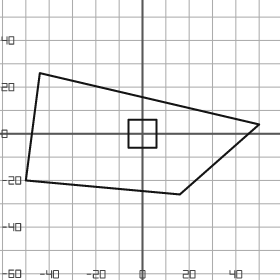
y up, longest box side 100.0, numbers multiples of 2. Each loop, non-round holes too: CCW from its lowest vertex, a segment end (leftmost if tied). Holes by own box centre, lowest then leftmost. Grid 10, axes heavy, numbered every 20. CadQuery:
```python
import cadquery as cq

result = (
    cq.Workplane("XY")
    .moveTo(16.0, -26.0)
    .lineTo(50.0, 4.0)
    .lineTo(-44.0, 26.0)
    .lineTo(-50.0, -20.0)
    .close()
    .moveTo(-6.0, -6.0)
    .lineTo(6.0, -6.0)
    .lineTo(6.0, 6.0)
    .lineTo(-6.0, 6.0)
    .close()
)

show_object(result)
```